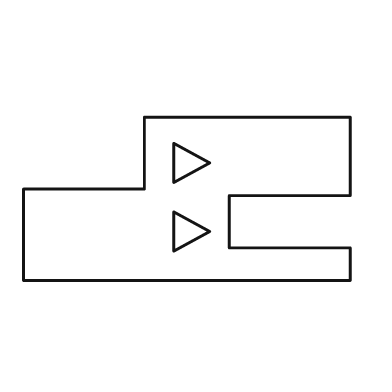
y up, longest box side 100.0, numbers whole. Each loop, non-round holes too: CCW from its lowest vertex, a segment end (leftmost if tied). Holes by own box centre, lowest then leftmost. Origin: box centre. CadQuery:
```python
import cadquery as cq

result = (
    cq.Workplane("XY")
    .moveTo(-50.0, -25.0)
    .lineTo(50.0, -25.0)
    .lineTo(50.0, -15.0)
    .lineTo(13.0, -15.0)
    .lineTo(13.0, 1.0)
    .lineTo(50.0, 1.0)
    .lineTo(50.0, 25.0)
    .lineTo(-13.0, 25.0)
    .lineTo(-13.0, 3.0)
    .lineTo(-50.0, 3.0)
    .close()
    .moveTo(-4.0, -16.0)
    .lineTo(7.0, -10.0)
    .lineTo(-4.0, -4.0)
    .close()
    .moveTo(-4.0, 5.0)
    .lineTo(7.0, 11.0)
    .lineTo(-4.0, 17.0)
    .close()
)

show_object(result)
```